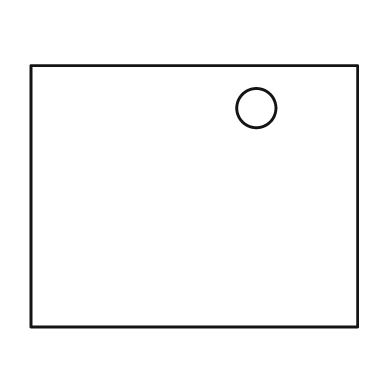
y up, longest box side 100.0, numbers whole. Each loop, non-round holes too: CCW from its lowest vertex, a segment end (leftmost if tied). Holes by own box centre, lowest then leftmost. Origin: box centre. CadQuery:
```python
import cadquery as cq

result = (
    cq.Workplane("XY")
    .moveTo(-50.0, -40.0)
    .lineTo(50.0, -40.0)
    .lineTo(50.0, 40.0)
    .lineTo(-50.0, 40.0)
    .close()
    .moveTo(19.0, 27.0)
    .circle(6.0)
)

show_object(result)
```